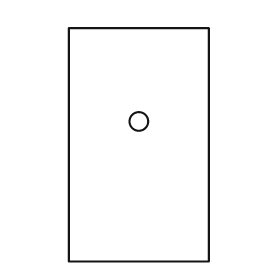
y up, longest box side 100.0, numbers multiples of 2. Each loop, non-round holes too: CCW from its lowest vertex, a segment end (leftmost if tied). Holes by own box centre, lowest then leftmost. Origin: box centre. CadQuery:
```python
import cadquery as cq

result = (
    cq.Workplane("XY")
    .moveTo(-30.0, -50.0)
    .lineTo(30.0, -50.0)
    .lineTo(30.0, 50.0)
    .lineTo(-30.0, 50.0)
    .close()
    .moveTo(0.0, 10.0)
    .circle(4.0)
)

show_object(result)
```